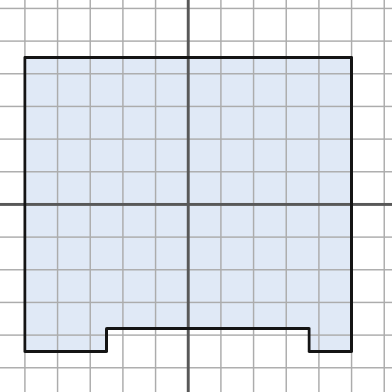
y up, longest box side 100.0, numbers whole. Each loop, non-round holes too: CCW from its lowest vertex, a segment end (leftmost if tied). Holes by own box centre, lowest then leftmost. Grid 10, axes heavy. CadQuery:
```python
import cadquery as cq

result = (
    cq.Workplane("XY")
    .moveTo(-50.0, -45.0)
    .lineTo(-25.0, -45.0)
    .lineTo(-25.0, -38.0)
    .lineTo(37.0, -38.0)
    .lineTo(37.0, -45.0)
    .lineTo(50.0, -45.0)
    .lineTo(50.0, 45.0)
    .lineTo(-50.0, 45.0)
    .close()
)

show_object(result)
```